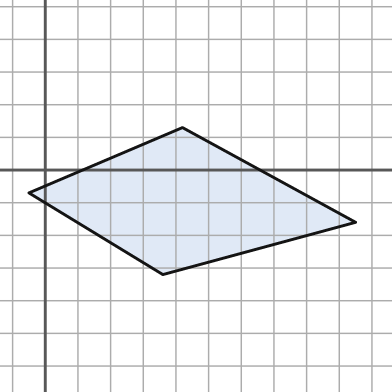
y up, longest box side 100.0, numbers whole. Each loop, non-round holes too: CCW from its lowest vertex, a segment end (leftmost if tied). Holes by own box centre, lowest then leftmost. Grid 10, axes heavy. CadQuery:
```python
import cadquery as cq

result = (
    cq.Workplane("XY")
    .moveTo(36.0, -32.0)
    .lineTo(95.0, -16.0)
    .lineTo(42.0, 13.0)
    .lineTo(-5.0, -7.0)
    .close()
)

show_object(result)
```